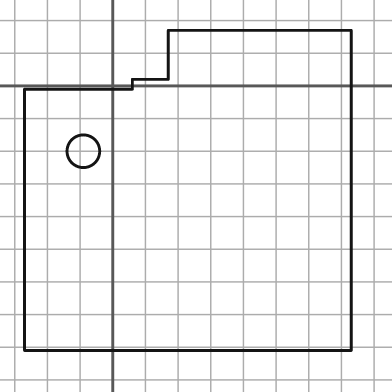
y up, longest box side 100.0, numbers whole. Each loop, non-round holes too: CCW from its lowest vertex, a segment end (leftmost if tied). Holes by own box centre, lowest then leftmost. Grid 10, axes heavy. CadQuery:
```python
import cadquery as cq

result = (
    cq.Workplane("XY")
    .moveTo(-27.0, -81.0)
    .lineTo(73.0, -81.0)
    .lineTo(73.0, 17.0)
    .lineTo(17.0, 17.0)
    .lineTo(17.0, 2.0)
    .lineTo(6.0, 2.0)
    .lineTo(6.0, -1.0)
    .lineTo(-27.0, -1.0)
    .close()
    .moveTo(-9.0, -20.0)
    .circle(5.0)
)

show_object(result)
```